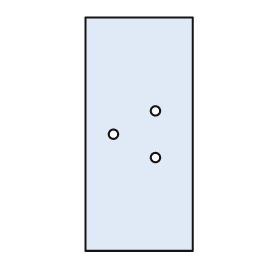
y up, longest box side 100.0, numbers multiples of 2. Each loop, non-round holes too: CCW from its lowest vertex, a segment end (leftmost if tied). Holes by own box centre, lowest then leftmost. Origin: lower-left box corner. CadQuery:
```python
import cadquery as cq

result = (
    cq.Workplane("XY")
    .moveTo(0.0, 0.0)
    .lineTo(46.0, 0.0)
    .lineTo(46.0, 100.0)
    .lineTo(0.0, 100.0)
    .close()
    .moveTo(30.0, 40.0)
    .circle(2.0)
    .moveTo(12.0, 50.0)
    .circle(2.0)
    .moveTo(30.0, 60.0)
    .circle(2.0)
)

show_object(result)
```